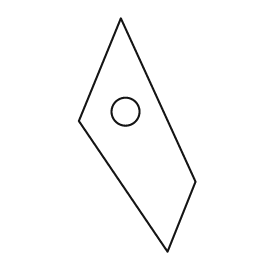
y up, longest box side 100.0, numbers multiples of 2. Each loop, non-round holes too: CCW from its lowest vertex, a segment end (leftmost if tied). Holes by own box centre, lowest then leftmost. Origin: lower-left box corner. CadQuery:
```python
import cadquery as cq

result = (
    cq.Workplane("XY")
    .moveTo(38.0, 0.0)
    .lineTo(50.0, 30.0)
    .lineTo(18.0, 100.0)
    .lineTo(0.0, 56.0)
    .close()
    .moveTo(20.0, 60.0)
    .circle(6.0)
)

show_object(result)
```